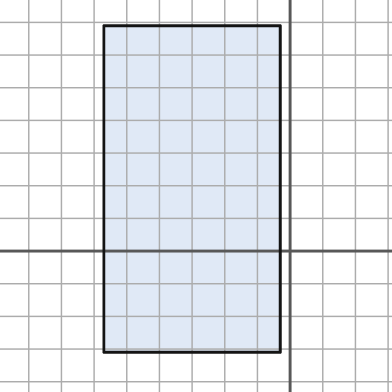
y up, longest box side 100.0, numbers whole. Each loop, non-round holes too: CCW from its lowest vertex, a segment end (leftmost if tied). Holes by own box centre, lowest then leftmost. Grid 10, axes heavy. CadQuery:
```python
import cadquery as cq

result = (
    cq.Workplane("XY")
    .moveTo(-57.0, -31.0)
    .lineTo(-3.0, -31.0)
    .lineTo(-3.0, 69.0)
    .lineTo(-57.0, 69.0)
    .close()
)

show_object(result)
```